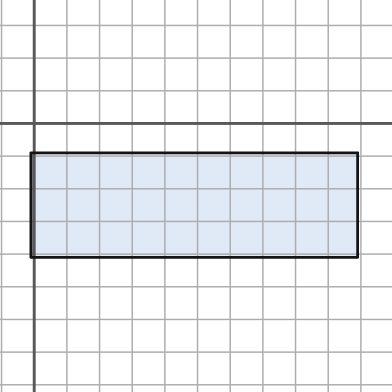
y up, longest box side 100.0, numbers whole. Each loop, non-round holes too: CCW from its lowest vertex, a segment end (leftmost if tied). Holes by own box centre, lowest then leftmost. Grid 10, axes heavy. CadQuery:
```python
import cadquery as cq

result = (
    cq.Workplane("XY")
    .moveTo(-1.0, -41.0)
    .lineTo(99.0, -41.0)
    .lineTo(99.0, -9.0)
    .lineTo(-1.0, -9.0)
    .close()
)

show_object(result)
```